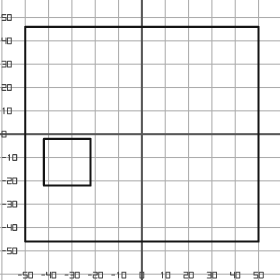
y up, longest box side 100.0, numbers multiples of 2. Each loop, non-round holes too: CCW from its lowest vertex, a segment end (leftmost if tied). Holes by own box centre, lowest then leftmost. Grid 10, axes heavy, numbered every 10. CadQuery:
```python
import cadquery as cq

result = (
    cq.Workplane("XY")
    .moveTo(-50.0, -46.0)
    .lineTo(50.0, -46.0)
    .lineTo(50.0, 46.0)
    .lineTo(-50.0, 46.0)
    .close()
    .moveTo(-42.0, -22.0)
    .lineTo(-22.0, -22.0)
    .lineTo(-22.0, -2.0)
    .lineTo(-42.0, -2.0)
    .close()
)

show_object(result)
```